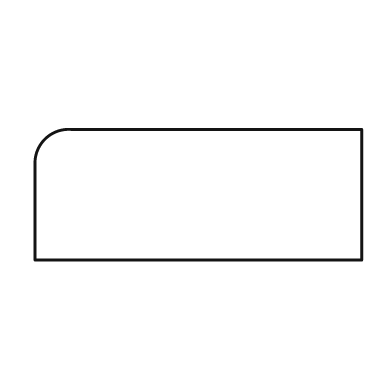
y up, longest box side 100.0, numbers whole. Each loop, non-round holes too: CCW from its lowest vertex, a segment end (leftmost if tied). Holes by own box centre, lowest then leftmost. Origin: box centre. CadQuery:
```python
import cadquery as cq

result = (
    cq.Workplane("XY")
    .moveTo(-50.0, -20.0)
    .lineTo(50.0, -20.0)
    .lineTo(50.0, 20.0)
    .lineTo(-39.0, 20.0)
    .threePointArc((-47.0, 17.0), (-50.0, 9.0))
    .close()
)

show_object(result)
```